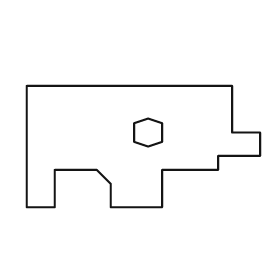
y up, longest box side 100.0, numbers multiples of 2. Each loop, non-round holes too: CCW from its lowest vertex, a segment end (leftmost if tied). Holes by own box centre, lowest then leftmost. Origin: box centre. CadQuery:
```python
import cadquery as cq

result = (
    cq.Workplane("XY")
    .moveTo(-50.0, -26.0)
    .lineTo(-38.0, -26.0)
    .lineTo(-38.0, -10.0)
    .lineTo(-20.0, -10.0)
    .lineTo(-14.0, -16.0)
    .lineTo(-14.0, -26.0)
    .lineTo(8.0, -26.0)
    .lineTo(8.0, -10.0)
    .lineTo(32.0, -10.0)
    .lineTo(32.0, -4.0)
    .lineTo(50.0, -4.0)
    .lineTo(50.0, 6.0)
    .lineTo(38.0, 6.0)
    .lineTo(38.0, 26.0)
    .lineTo(-50.0, 26.0)
    .close()
    .moveTo(2.0, 0.0)
    .lineTo(8.0, 2.0)
    .lineTo(8.0, 10.0)
    .lineTo(2.0, 12.0)
    .lineTo(-4.0, 10.0)
    .lineTo(-4.0, 2.0)
    .close()
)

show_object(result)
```